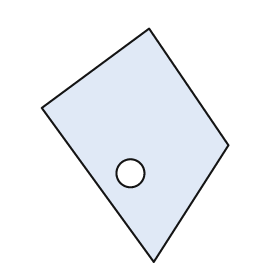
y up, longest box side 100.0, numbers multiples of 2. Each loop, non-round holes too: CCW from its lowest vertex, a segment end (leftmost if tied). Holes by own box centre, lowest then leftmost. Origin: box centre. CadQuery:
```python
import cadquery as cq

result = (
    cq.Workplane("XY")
    .moveTo(8.0, -50.0)
    .lineTo(40.0, 0.0)
    .lineTo(6.0, 50.0)
    .lineTo(-40.0, 16.0)
    .close()
    .moveTo(-2.0, -12.0)
    .circle(6.0)
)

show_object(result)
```